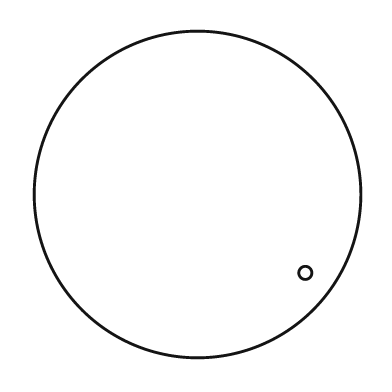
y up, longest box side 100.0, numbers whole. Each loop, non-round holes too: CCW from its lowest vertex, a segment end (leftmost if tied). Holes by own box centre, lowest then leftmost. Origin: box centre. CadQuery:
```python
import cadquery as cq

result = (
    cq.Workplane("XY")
    .moveTo(0.0, 0.0)
    .circle(50.0)
    .moveTo(33.0, -24.0)
    .circle(2.0)
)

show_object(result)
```